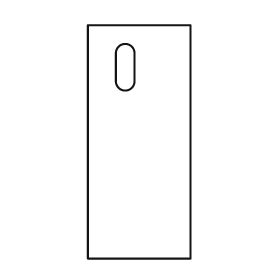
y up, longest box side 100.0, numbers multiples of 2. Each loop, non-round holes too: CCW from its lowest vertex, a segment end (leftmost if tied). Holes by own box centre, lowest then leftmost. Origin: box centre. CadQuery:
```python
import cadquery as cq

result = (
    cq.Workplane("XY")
    .moveTo(-22.0, -50.0)
    .lineTo(22.0, -50.0)
    .lineTo(22.0, 50.0)
    .lineTo(-22.0, 50.0)
    .close()
    .moveTo(-10.0, 26.0)
    .threePointArc((-6.0, 22.0), (-2.0, 26.0))
    .lineTo(-2.0, 38.0)
    .threePointArc((-6.0, 42.0), (-10.0, 38.0))
    .close()
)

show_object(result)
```